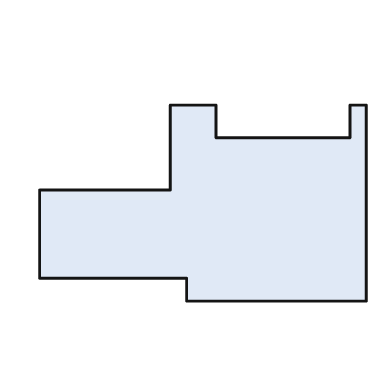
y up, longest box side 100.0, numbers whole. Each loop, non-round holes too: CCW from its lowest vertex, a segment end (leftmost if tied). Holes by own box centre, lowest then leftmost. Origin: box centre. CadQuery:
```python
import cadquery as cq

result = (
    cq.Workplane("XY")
    .moveTo(-5.0, -30.0)
    .lineTo(50.0, -30.0)
    .lineTo(50.0, 30.0)
    .lineTo(45.0, 30.0)
    .lineTo(45.0, 20.0)
    .lineTo(4.0, 20.0)
    .lineTo(4.0, 30.0)
    .lineTo(-10.0, 30.0)
    .lineTo(-10.0, 4.0)
    .lineTo(-50.0, 4.0)
    .lineTo(-50.0, -23.0)
    .lineTo(-5.0, -23.0)
    .close()
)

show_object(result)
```